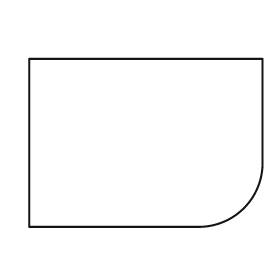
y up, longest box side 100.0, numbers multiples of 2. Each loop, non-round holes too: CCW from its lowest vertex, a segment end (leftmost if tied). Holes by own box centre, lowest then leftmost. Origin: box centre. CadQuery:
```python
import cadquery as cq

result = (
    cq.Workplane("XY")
    .moveTo(-50.0, -36.0)
    .lineTo(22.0, -36.0)
    .threePointArc((42.0, -28.0), (50.0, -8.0))
    .lineTo(50.0, 36.0)
    .lineTo(-50.0, 36.0)
    .close()
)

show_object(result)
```